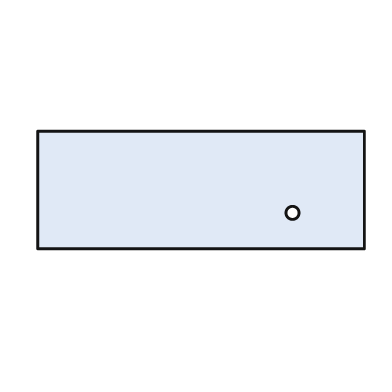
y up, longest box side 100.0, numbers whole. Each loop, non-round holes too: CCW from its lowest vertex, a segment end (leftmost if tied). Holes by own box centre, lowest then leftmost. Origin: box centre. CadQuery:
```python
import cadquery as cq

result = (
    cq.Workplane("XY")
    .moveTo(-50.0, -18.0)
    .lineTo(50.0, -18.0)
    .lineTo(50.0, 18.0)
    .lineTo(-50.0, 18.0)
    .close()
    .moveTo(28.0, -7.0)
    .circle(2.0)
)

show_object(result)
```